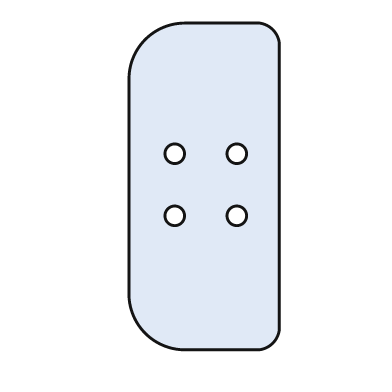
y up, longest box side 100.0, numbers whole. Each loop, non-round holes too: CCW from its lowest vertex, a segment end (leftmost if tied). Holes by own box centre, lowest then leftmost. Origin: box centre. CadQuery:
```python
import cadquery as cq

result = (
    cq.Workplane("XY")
    .moveTo(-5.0, -50.0)
    .lineTo(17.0, -50.0)
    .threePointArc((21.0, -48.0), (23.0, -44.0))
    .lineTo(23.0, 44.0)
    .threePointArc((21.0, 48.0), (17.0, 50.0))
    .lineTo(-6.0, 50.0)
    .threePointArc((-18.0, 45.0), (-23.0, 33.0))
    .lineTo(-23.0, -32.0)
    .threePointArc((-18.0, -45.0), (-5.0, -50.0))
    .close()
    .moveTo(-9.0, -9.0)
    .circle(3.0)
    .moveTo(10.0, -9.0)
    .circle(3.0)
    .moveTo(-9.0, 10.0)
    .circle(3.0)
    .moveTo(10.0, 10.0)
    .circle(3.0)
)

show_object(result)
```